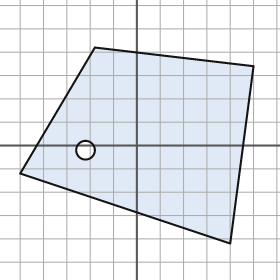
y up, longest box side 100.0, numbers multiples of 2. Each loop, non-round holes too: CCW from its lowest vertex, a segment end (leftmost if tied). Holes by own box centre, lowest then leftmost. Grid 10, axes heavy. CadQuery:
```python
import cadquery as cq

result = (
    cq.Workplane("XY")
    .moveTo(40.0, -42.0)
    .lineTo(50.0, 34.0)
    .lineTo(-18.0, 42.0)
    .lineTo(-50.0, -12.0)
    .close()
    .moveTo(-22.0, -2.0)
    .circle(4.0)
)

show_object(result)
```